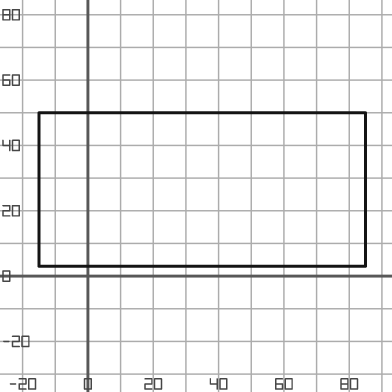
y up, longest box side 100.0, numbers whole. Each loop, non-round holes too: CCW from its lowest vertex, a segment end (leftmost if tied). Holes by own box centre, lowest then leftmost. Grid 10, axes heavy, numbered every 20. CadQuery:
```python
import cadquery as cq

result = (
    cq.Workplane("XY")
    .moveTo(-15.0, 3.0)
    .lineTo(85.0, 3.0)
    .lineTo(85.0, 50.0)
    .lineTo(-15.0, 50.0)
    .close()
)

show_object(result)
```